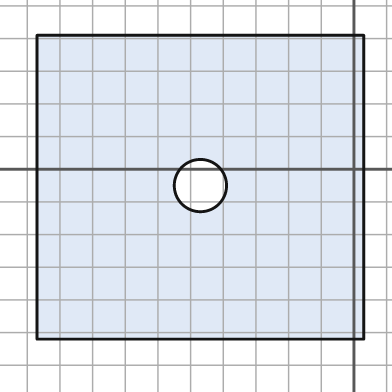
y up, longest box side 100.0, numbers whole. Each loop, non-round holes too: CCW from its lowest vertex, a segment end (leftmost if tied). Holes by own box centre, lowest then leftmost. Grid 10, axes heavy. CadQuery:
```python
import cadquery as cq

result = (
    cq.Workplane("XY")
    .moveTo(-97.0, -52.0)
    .lineTo(3.0, -52.0)
    .lineTo(3.0, 41.0)
    .lineTo(-97.0, 41.0)
    .close()
    .moveTo(-47.0, -5.0)
    .circle(8.0)
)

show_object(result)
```